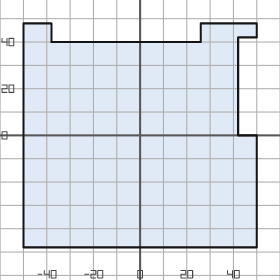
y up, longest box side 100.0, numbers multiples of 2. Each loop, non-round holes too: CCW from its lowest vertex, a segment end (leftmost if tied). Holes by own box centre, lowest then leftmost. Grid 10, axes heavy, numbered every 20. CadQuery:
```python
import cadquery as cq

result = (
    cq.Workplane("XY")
    .moveTo(-50.0, -48.0)
    .lineTo(50.0, -48.0)
    .lineTo(50.0, 0.0)
    .lineTo(42.0, 0.0)
    .lineTo(42.0, 42.0)
    .lineTo(50.0, 42.0)
    .lineTo(50.0, 48.0)
    .lineTo(26.0, 48.0)
    .lineTo(26.0, 40.0)
    .lineTo(-38.0, 40.0)
    .lineTo(-38.0, 48.0)
    .lineTo(-50.0, 48.0)
    .close()
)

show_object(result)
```